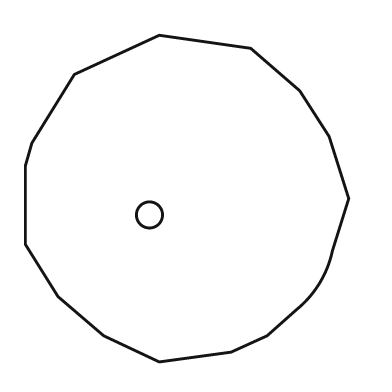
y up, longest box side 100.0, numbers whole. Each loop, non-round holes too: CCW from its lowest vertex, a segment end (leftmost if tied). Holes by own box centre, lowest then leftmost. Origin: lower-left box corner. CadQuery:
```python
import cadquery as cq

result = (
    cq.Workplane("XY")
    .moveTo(41.0, 0.0)
    .lineTo(63.0, 3.0)
    .lineTo(74.0, 8.0)
    .lineTo(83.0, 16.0)
    .threePointArc((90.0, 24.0), (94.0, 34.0))
    .lineTo(99.0, 50.0)
    .lineTo(93.0, 69.0)
    .lineTo(84.0, 83.0)
    .lineTo(69.0, 96.0)
    .lineTo(41.0, 100.0)
    .lineTo(15.0, 88.0)
    .lineTo(2.0, 67.0)
    .lineTo(0.0, 60.0)
    .lineTo(0.0, 36.0)
    .lineTo(10.0, 20.0)
    .lineTo(24.0, 8.0)
    .close()
    .moveTo(38.0, 45.0)
    .circle(4.0)
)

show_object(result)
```